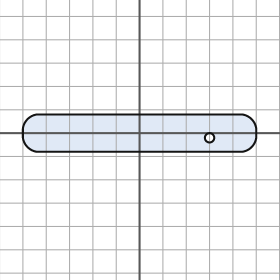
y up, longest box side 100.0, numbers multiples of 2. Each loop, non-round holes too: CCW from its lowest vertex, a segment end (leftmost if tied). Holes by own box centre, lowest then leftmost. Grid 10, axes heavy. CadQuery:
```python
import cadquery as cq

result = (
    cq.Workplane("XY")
    .moveTo(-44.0, -8.0)
    .lineTo(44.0, -8.0)
    .threePointArc((48.0, -6.0), (50.0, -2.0))
    .lineTo(50.0, 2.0)
    .threePointArc((48.0, 6.0), (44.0, 8.0))
    .lineTo(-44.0, 8.0)
    .threePointArc((-48.0, 6.0), (-50.0, 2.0))
    .lineTo(-50.0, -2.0)
    .threePointArc((-48.0, -6.0), (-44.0, -8.0))
    .close()
    .moveTo(30.0, -2.0)
    .circle(2.0)
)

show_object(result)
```